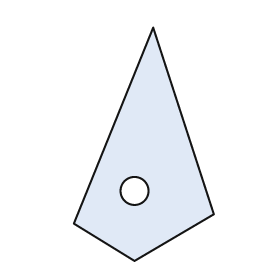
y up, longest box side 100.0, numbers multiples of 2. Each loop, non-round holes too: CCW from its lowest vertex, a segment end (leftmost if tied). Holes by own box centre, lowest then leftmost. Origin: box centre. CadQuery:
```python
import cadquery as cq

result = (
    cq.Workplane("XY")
    .moveTo(-4.0, -50.0)
    .lineTo(30.0, -30.0)
    .lineTo(4.0, 50.0)
    .lineTo(-30.0, -34.0)
    .close()
    .moveTo(-4.0, -20.0)
    .circle(6.0)
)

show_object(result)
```